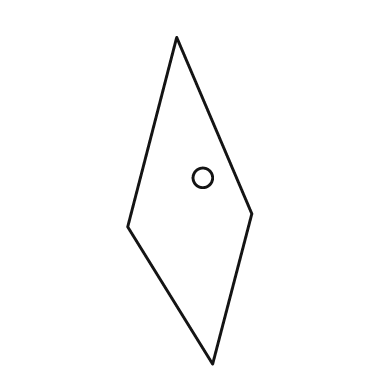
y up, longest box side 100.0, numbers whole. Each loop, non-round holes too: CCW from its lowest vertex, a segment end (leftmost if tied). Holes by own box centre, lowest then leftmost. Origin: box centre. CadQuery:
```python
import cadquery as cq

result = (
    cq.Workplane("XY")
    .moveTo(7.0, -50.0)
    .lineTo(19.0, -4.0)
    .lineTo(-4.0, 50.0)
    .lineTo(-19.0, -8.0)
    .close()
    .moveTo(4.0, 7.0)
    .circle(3.0)
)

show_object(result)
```